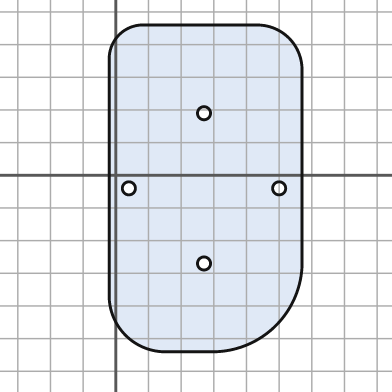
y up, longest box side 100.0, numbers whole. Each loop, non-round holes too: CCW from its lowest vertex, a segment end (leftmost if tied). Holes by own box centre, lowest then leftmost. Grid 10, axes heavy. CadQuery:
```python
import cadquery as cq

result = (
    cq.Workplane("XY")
    .moveTo(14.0, -54.0)
    .lineTo(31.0, -54.0)
    .threePointArc((49.0, -46.0), (57.0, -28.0))
    .lineTo(57.0, 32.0)
    .threePointArc((53.0, 42.0), (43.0, 46.0))
    .lineTo(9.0, 46.0)
    .threePointArc((1.0, 43.0), (-2.0, 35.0))
    .lineTo(-2.0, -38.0)
    .threePointArc((3.0, -49.0), (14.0, -54.0))
    .close()
    .moveTo(27.0, -27.0)
    .circle(2.0)
    .moveTo(4.0, -4.0)
    .circle(2.0)
    .moveTo(50.0, -4.0)
    .circle(2.0)
    .moveTo(27.0, 19.0)
    .circle(2.0)
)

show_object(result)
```